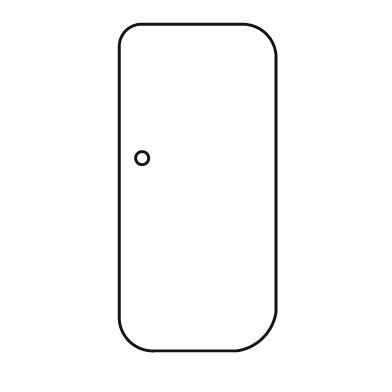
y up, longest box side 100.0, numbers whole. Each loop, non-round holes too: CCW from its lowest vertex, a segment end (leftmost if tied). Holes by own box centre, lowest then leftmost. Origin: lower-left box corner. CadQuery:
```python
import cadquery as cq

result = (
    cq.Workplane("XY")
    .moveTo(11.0, 0.0)
    .lineTo(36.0, 0.0)
    .threePointArc((44.0, 4.0), (48.0, 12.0))
    .lineTo(48.0, 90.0)
    .threePointArc((45.0, 97.0), (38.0, 100.0))
    .lineTo(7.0, 100.0)
    .threePointArc((2.0, 98.0), (0.0, 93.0))
    .lineTo(0.0, 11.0)
    .threePointArc((3.0, 3.0), (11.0, 0.0))
    .close()
    .moveTo(7.0, 59.0)
    .circle(2.0)
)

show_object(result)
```